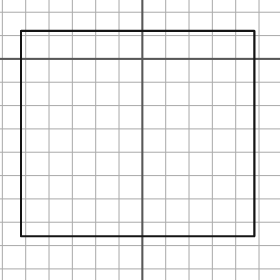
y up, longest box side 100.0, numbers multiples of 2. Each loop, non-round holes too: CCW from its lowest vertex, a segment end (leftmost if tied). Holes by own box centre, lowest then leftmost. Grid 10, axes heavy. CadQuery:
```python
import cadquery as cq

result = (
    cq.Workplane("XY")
    .moveTo(-52.0, -76.0)
    .lineTo(48.0, -76.0)
    .lineTo(48.0, 12.0)
    .lineTo(-52.0, 12.0)
    .close()
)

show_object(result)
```